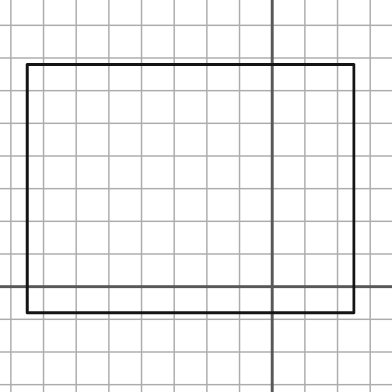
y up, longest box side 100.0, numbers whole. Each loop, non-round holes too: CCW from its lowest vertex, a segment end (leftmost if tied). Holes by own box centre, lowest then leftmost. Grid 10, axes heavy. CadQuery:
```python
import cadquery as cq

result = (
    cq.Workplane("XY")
    .moveTo(-75.0, -8.0)
    .lineTo(25.0, -8.0)
    .lineTo(25.0, 68.0)
    .lineTo(-75.0, 68.0)
    .close()
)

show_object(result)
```